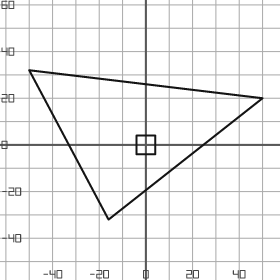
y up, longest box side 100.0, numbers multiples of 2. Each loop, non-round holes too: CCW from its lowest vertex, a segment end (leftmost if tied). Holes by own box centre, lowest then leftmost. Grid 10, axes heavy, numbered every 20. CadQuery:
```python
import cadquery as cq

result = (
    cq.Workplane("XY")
    .moveTo(-16.0, -32.0)
    .lineTo(50.0, 20.0)
    .lineTo(-50.0, 32.0)
    .close()
    .moveTo(-4.0, -4.0)
    .lineTo(4.0, -4.0)
    .lineTo(4.0, 4.0)
    .lineTo(-4.0, 4.0)
    .close()
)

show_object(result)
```